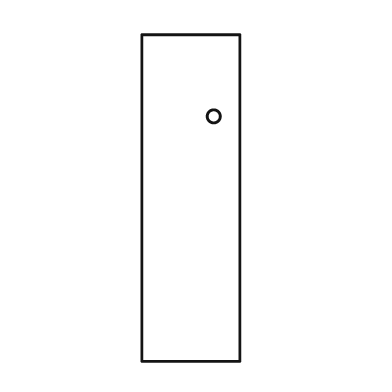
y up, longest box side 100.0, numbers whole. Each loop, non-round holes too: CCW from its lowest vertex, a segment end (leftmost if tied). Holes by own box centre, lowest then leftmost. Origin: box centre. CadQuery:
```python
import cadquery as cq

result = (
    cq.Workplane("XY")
    .moveTo(-15.0, -50.0)
    .lineTo(15.0, -50.0)
    .lineTo(15.0, 50.0)
    .lineTo(-15.0, 50.0)
    .close()
    .moveTo(7.0, 25.0)
    .circle(2.0)
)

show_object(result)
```